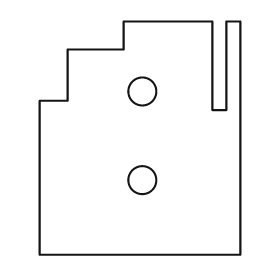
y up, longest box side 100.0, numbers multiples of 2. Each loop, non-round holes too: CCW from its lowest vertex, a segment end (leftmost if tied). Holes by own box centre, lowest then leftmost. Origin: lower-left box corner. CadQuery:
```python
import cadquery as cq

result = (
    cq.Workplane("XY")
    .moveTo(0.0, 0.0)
    .lineTo(86.0, 0.0)
    .lineTo(86.0, 100.0)
    .lineTo(80.0, 100.0)
    .lineTo(80.0, 62.0)
    .lineTo(74.0, 62.0)
    .lineTo(74.0, 100.0)
    .lineTo(36.0, 100.0)
    .lineTo(36.0, 88.0)
    .lineTo(12.0, 88.0)
    .lineTo(12.0, 66.0)
    .lineTo(0.0, 66.0)
    .close()
    .moveTo(44.0, 32.0)
    .circle(6.0)
    .moveTo(44.0, 70.0)
    .circle(6.0)
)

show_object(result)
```